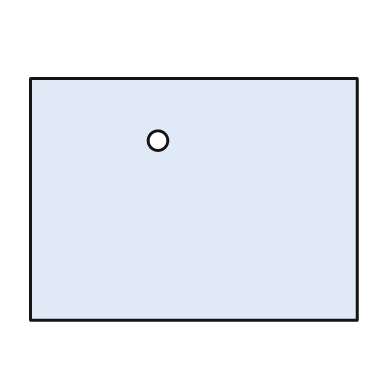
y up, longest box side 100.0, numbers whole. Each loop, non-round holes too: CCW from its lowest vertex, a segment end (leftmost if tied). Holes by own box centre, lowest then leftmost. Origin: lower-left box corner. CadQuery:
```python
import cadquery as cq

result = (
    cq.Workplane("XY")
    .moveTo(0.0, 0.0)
    .lineTo(100.0, 0.0)
    .lineTo(100.0, 74.0)
    .lineTo(0.0, 74.0)
    .close()
    .moveTo(39.0, 55.0)
    .circle(3.0)
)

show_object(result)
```